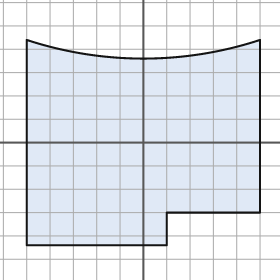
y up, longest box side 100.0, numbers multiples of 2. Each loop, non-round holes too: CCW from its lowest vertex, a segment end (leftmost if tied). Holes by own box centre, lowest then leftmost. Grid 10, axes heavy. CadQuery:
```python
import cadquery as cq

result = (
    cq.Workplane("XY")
    .moveTo(-50.0, -44.0)
    .lineTo(10.0, -44.0)
    .lineTo(10.0, -30.0)
    .lineTo(50.0, -30.0)
    .lineTo(50.0, 44.0)
    .threePointArc((0.0, 36.0), (-50.0, 44.0))
    .close()
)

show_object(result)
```